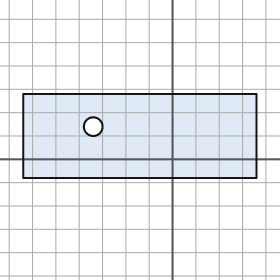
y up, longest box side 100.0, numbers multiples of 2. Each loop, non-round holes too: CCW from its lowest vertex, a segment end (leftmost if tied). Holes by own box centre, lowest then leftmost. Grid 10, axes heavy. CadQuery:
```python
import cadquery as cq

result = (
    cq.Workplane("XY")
    .moveTo(-64.0, -8.0)
    .lineTo(36.0, -8.0)
    .lineTo(36.0, 28.0)
    .lineTo(-64.0, 28.0)
    .close()
    .moveTo(-34.0, 14.0)
    .circle(4.0)
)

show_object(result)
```